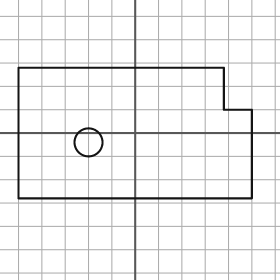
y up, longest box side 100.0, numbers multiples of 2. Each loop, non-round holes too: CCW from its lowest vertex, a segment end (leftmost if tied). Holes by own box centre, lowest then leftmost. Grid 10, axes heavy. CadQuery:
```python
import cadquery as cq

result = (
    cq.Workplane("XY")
    .moveTo(-50.0, -28.0)
    .lineTo(50.0, -28.0)
    .lineTo(50.0, 10.0)
    .lineTo(38.0, 10.0)
    .lineTo(38.0, 28.0)
    .lineTo(-50.0, 28.0)
    .close()
    .moveTo(-20.0, -4.0)
    .circle(6.0)
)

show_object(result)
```